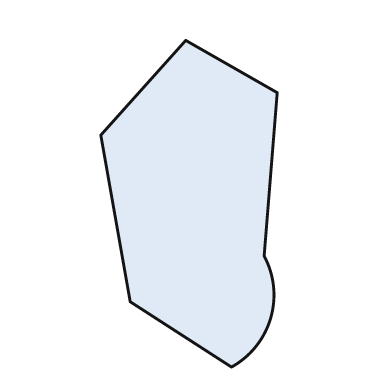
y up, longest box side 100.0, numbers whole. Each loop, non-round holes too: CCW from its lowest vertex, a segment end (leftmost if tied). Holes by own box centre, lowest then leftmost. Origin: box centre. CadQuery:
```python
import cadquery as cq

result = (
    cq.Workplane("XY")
    .moveTo(13.0, -50.0)
    .threePointArc((25.0, -35.0), (23.0, -16.0))
    .lineTo(27.0, 34.0)
    .lineTo(-1.0, 50.0)
    .lineTo(-27.0, 21.0)
    .lineTo(-18.0, -30.0)
    .close()
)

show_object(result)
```